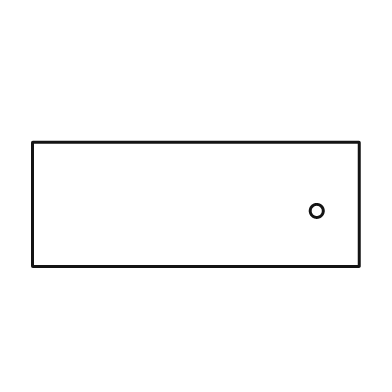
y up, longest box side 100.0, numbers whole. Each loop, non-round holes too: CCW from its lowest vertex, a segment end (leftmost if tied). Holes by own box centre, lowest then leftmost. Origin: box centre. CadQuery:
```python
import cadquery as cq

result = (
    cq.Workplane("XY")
    .moveTo(-50.0, -19.0)
    .lineTo(50.0, -19.0)
    .lineTo(50.0, 19.0)
    .lineTo(-50.0, 19.0)
    .close()
    .moveTo(37.0, -2.0)
    .circle(2.0)
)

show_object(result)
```